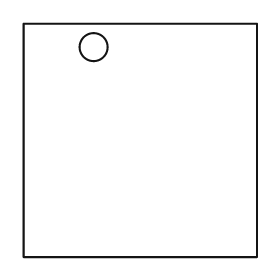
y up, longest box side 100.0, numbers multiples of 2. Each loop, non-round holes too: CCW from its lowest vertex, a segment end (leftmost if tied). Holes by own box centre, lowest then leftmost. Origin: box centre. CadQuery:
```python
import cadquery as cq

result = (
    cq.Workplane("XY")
    .moveTo(-50.0, -50.0)
    .lineTo(50.0, -50.0)
    .lineTo(50.0, 50.0)
    .lineTo(-50.0, 50.0)
    .close()
    .moveTo(-20.0, 40.0)
    .circle(6.0)
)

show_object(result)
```